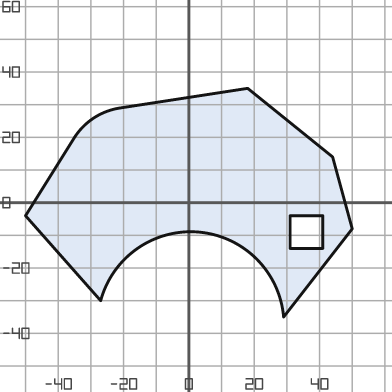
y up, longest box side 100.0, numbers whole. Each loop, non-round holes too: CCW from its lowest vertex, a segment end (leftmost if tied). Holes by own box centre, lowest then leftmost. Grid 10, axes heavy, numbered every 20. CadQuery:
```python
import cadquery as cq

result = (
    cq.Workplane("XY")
    .moveTo(29.0, -35.0)
    .lineTo(50.0, -8.0)
    .lineTo(44.0, 14.0)
    .lineTo(18.0, 35.0)
    .lineTo(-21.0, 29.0)
    .threePointArc((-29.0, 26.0), (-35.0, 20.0))
    .lineTo(-50.0, -4.0)
    .lineTo(-27.0, -30.0)
    .threePointArc((3.0, -9.0), (29.0, -35.0))
    .close()
    .moveTo(31.0, -14.0)
    .lineTo(41.0, -14.0)
    .lineTo(41.0, -4.0)
    .lineTo(31.0, -4.0)
    .close()
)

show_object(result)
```